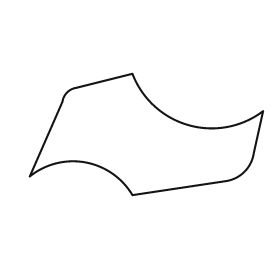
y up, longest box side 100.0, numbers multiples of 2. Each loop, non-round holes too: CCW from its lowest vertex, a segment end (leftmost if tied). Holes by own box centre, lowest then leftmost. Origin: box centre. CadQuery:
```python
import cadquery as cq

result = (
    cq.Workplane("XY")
    .moveTo(-6.0, -26.0)
    .lineTo(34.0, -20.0)
    .threePointArc((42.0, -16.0), (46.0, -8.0))
    .lineTo(50.0, 10.0)
    .threePointArc((18.0, 4.0), (-6.0, 26.0))
    .lineTo(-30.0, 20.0)
    .threePointArc((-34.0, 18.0), (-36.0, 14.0))
    .lineTo(-50.0, -18.0)
    .threePointArc((-26.0, -12.0), (-6.0, -26.0))
    .close()
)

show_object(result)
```